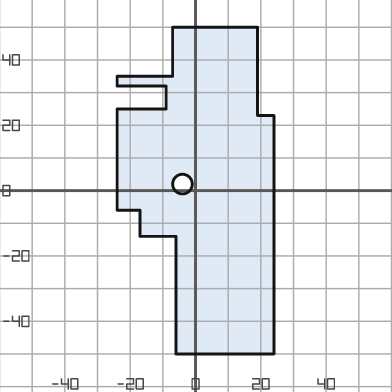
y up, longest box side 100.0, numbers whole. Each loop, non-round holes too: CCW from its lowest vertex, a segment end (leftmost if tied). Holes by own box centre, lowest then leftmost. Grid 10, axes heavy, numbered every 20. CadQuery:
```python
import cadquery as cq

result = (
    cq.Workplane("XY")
    .moveTo(-6.0, -50.0)
    .lineTo(24.0, -50.0)
    .lineTo(24.0, 23.0)
    .lineTo(19.0, 23.0)
    .lineTo(19.0, 50.0)
    .lineTo(-7.0, 50.0)
    .lineTo(-7.0, 35.0)
    .lineTo(-24.0, 35.0)
    .lineTo(-24.0, 32.0)
    .lineTo(-9.0, 32.0)
    .lineTo(-9.0, 25.0)
    .lineTo(-24.0, 25.0)
    .lineTo(-24.0, -6.0)
    .lineTo(-17.0, -6.0)
    .lineTo(-17.0, -14.0)
    .lineTo(-6.0, -14.0)
    .close()
    .moveTo(-4.0, 2.0)
    .circle(3.0)
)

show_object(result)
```